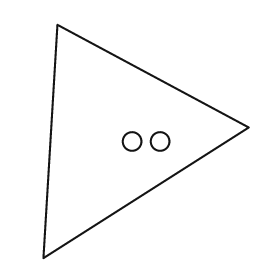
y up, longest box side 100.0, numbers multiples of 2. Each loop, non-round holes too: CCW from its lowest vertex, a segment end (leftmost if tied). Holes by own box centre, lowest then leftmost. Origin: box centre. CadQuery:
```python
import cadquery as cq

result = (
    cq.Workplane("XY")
    .moveTo(-44.0, -50.0)
    .lineTo(44.0, 6.0)
    .lineTo(-38.0, 50.0)
    .close()
    .moveTo(-6.0, 0.0)
    .circle(4.0)
    .moveTo(6.0, 0.0)
    .circle(4.0)
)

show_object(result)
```